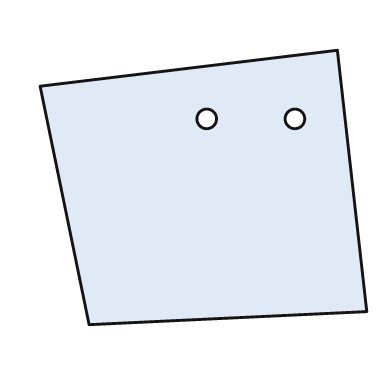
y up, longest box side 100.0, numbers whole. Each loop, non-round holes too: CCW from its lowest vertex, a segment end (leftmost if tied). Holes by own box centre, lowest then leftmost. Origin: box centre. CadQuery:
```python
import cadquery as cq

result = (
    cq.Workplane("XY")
    .moveTo(-35.0, -42.0)
    .lineTo(50.0, -38.0)
    .lineTo(41.0, 42.0)
    .lineTo(-50.0, 31.0)
    .close()
    .moveTo(1.0, 21.0)
    .circle(3.0)
    .moveTo(28.0, 21.0)
    .circle(3.0)
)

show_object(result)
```